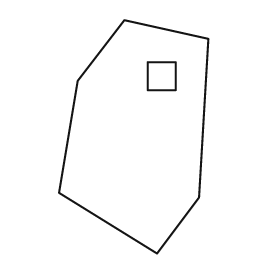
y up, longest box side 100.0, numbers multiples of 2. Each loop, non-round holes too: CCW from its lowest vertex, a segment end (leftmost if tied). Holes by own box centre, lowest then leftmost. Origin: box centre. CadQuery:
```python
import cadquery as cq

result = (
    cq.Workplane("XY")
    .moveTo(10.0, -50.0)
    .lineTo(28.0, -26.0)
    .lineTo(32.0, 42.0)
    .lineTo(-4.0, 50.0)
    .lineTo(-24.0, 24.0)
    .lineTo(-32.0, -24.0)
    .close()
    .moveTo(6.0, 20.0)
    .lineTo(18.0, 20.0)
    .lineTo(18.0, 32.0)
    .lineTo(6.0, 32.0)
    .close()
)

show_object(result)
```